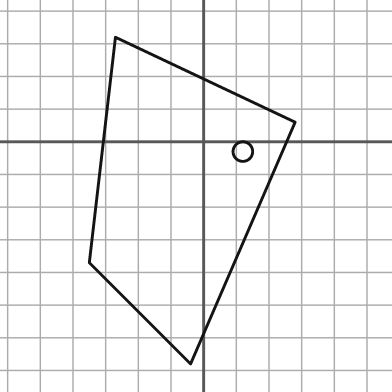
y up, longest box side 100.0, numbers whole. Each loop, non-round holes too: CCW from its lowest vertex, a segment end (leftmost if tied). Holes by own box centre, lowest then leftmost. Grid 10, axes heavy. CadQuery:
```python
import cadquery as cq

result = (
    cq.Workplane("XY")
    .moveTo(-4.0, -68.0)
    .lineTo(28.0, 6.0)
    .lineTo(-27.0, 32.0)
    .lineTo(-35.0, -37.0)
    .close()
    .moveTo(12.0, -3.0)
    .circle(3.0)
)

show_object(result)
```